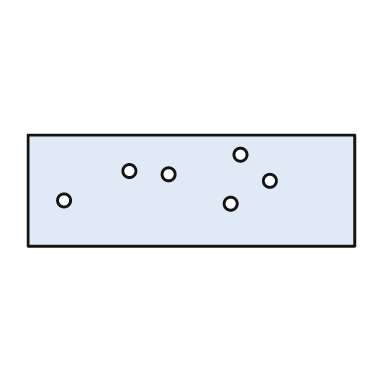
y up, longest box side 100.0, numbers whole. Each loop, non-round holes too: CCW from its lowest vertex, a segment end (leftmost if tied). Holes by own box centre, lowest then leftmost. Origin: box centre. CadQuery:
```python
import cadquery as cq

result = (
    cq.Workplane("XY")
    .moveTo(-50.0, -17.0)
    .lineTo(50.0, -17.0)
    .lineTo(50.0, 17.0)
    .lineTo(-50.0, 17.0)
    .close()
    .moveTo(12.0, -4.0)
    .circle(2.0)
    .moveTo(-39.0, -3.0)
    .circle(2.0)
    .moveTo(24.0, 3.0)
    .circle(2.0)
    .moveTo(-7.0, 5.0)
    .circle(2.0)
    .moveTo(-19.0, 6.0)
    .circle(2.0)
    .moveTo(15.0, 11.0)
    .circle(2.0)
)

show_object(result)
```